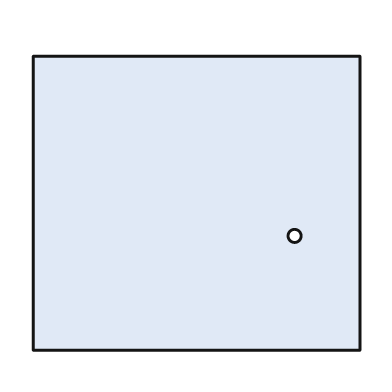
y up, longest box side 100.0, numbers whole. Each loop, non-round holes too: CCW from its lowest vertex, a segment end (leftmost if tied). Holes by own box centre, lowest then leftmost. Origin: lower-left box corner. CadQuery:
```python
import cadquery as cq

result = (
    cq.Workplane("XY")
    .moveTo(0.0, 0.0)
    .lineTo(100.0, 0.0)
    .lineTo(100.0, 90.0)
    .lineTo(0.0, 90.0)
    .close()
    .moveTo(80.0, 35.0)
    .circle(2.0)
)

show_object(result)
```